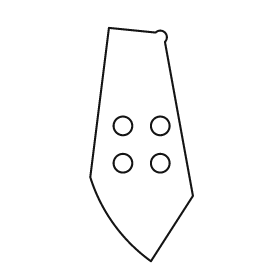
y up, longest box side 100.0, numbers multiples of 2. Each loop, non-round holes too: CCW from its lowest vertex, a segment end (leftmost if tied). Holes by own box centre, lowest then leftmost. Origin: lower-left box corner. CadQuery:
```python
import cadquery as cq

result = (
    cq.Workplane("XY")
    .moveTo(26.0, 0.0)
    .lineTo(44.0, 28.0)
    .lineTo(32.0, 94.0)
    .threePointArc((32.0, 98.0), (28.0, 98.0))
    .lineTo(8.0, 100.0)
    .lineTo(0.0, 36.0)
    .threePointArc((10.0, 16.0), (26.0, 0.0))
    .close()
    .moveTo(14.0, 42.0)
    .circle(4.0)
    .moveTo(30.0, 42.0)
    .circle(4.0)
    .moveTo(14.0, 58.0)
    .circle(4.0)
    .moveTo(30.0, 58.0)
    .circle(4.0)
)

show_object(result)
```